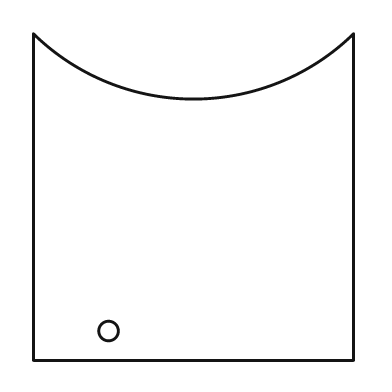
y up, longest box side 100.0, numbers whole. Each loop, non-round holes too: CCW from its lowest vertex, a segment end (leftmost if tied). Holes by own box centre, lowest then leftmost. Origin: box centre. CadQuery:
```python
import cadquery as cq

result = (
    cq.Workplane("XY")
    .moveTo(-49.0, -50.0)
    .lineTo(49.0, -50.0)
    .lineTo(49.0, 50.0)
    .threePointArc((0.0, 30.0), (-49.0, 50.0))
    .close()
    .moveTo(-26.0, -41.0)
    .circle(3.0)
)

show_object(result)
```